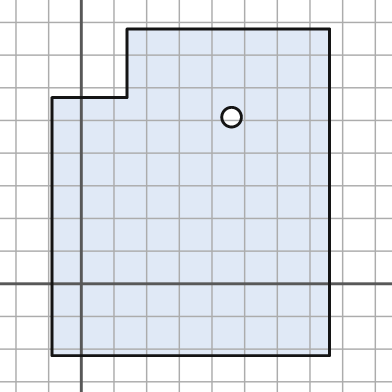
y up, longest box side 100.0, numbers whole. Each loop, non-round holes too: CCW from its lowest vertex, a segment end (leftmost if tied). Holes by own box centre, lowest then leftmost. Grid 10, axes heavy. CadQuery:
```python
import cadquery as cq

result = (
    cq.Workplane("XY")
    .moveTo(-9.0, -22.0)
    .lineTo(76.0, -22.0)
    .lineTo(76.0, 78.0)
    .lineTo(14.0, 78.0)
    .lineTo(14.0, 57.0)
    .lineTo(-9.0, 57.0)
    .close()
    .moveTo(46.0, 51.0)
    .circle(3.0)
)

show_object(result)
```